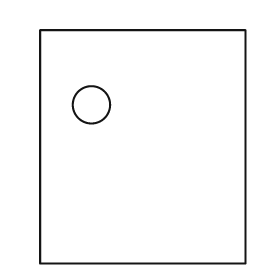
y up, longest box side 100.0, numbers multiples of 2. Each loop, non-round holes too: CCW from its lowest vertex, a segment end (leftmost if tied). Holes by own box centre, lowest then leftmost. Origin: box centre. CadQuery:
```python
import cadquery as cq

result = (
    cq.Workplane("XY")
    .moveTo(-44.0, -50.0)
    .lineTo(44.0, -50.0)
    .lineTo(44.0, 50.0)
    .lineTo(-44.0, 50.0)
    .close()
    .moveTo(-22.0, 18.0)
    .circle(8.0)
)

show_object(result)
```